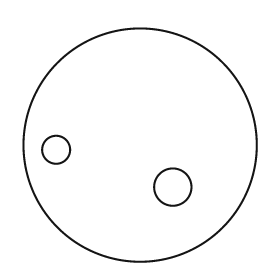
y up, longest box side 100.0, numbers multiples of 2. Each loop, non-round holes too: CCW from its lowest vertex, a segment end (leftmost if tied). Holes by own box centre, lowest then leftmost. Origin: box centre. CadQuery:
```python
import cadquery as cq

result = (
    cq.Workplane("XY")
    .moveTo(0.0, 0.0)
    .circle(50.0)
    .moveTo(14.0, -18.0)
    .circle(8.0)
    .moveTo(-36.0, -2.0)
    .circle(6.0)
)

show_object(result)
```